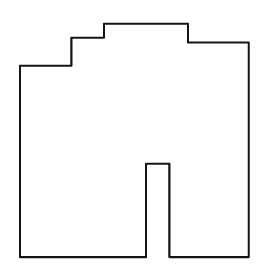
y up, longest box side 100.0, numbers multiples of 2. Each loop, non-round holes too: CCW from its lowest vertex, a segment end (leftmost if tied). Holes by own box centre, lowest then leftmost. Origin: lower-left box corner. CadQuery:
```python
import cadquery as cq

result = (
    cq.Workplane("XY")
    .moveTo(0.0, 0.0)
    .lineTo(54.0, 0.0)
    .lineTo(54.0, 40.0)
    .lineTo(64.0, 40.0)
    .lineTo(64.0, 0.0)
    .lineTo(98.0, 0.0)
    .lineTo(98.0, 92.0)
    .lineTo(72.0, 92.0)
    .lineTo(72.0, 100.0)
    .lineTo(36.0, 100.0)
    .lineTo(36.0, 94.0)
    .lineTo(22.0, 94.0)
    .lineTo(22.0, 82.0)
    .lineTo(0.0, 82.0)
    .close()
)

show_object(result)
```